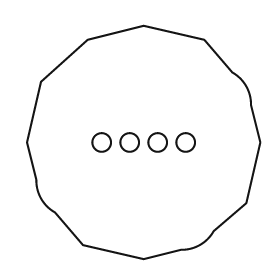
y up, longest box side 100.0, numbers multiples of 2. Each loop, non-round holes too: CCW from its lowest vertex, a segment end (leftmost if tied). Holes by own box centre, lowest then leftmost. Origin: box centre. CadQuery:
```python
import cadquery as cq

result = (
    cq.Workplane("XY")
    .moveTo(0.0, -50.0)
    .lineTo(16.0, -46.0)
    .threePointArc((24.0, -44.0), (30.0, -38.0))
    .lineTo(44.0, -26.0)
    .lineTo(50.0, 0.0)
    .lineTo(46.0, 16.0)
    .threePointArc((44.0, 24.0), (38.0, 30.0))
    .lineTo(26.0, 44.0)
    .lineTo(0.0, 50.0)
    .lineTo(-24.0, 44.0)
    .lineTo(-44.0, 26.0)
    .lineTo(-50.0, 0.0)
    .lineTo(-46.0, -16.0)
    .threePointArc((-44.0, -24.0), (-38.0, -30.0))
    .lineTo(-26.0, -44.0)
    .close()
    .moveTo(-18.0, 0.0)
    .circle(4.0)
    .moveTo(-6.0, 0.0)
    .circle(4.0)
    .moveTo(6.0, 0.0)
    .circle(4.0)
    .moveTo(18.0, 0.0)
    .circle(4.0)
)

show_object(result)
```